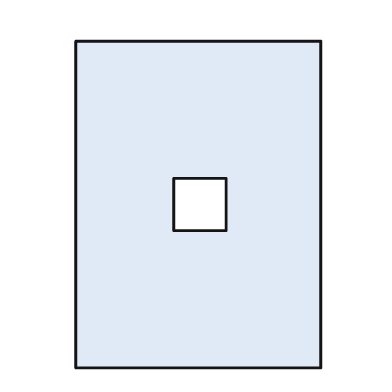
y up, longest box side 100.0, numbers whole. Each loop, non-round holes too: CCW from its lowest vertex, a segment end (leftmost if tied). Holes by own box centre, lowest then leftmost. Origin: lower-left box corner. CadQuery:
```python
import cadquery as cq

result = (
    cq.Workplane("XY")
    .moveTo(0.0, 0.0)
    .lineTo(75.0, 0.0)
    .lineTo(75.0, 100.0)
    .lineTo(0.0, 100.0)
    .close()
    .moveTo(30.0, 42.0)
    .lineTo(46.0, 42.0)
    .lineTo(46.0, 58.0)
    .lineTo(30.0, 58.0)
    .close()
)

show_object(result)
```